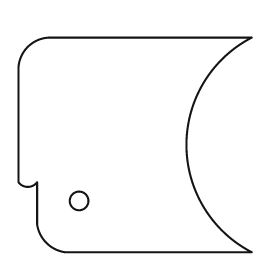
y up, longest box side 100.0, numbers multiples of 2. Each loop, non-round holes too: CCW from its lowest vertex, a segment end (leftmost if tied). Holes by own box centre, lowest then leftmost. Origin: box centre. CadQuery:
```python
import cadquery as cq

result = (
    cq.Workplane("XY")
    .moveTo(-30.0, -46.0)
    .lineTo(50.0, -46.0)
    .threePointArc((22.0, 0.0), (50.0, 46.0))
    .lineTo(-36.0, 46.0)
    .threePointArc((-46.0, 42.0), (-50.0, 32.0))
    .lineTo(-50.0, -16.0)
    .threePointArc((-46.0, -18.0), (-42.0, -16.0))
    .lineTo(-42.0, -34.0)
    .threePointArc((-38.0, -42.0), (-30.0, -46.0))
    .close()
    .moveTo(-24.0, -24.0)
    .circle(4.0)
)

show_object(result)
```